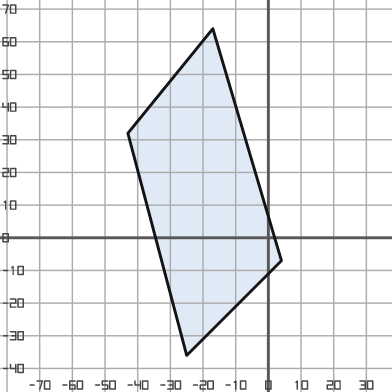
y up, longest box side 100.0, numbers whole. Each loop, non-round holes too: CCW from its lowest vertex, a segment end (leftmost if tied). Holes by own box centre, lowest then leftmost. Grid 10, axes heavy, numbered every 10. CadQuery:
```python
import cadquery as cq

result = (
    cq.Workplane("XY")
    .moveTo(-25.0, -36.0)
    .lineTo(4.0, -7.0)
    .lineTo(-17.0, 64.0)
    .lineTo(-43.0, 32.0)
    .close()
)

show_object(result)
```